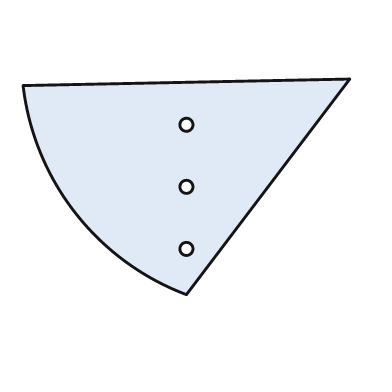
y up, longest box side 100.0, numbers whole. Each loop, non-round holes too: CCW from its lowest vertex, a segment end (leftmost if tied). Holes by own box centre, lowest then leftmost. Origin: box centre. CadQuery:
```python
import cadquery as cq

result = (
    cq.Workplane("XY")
    .moveTo(0.0, -33.0)
    .lineTo(50.0, 33.0)
    .lineTo(-50.0, 31.0)
    .threePointArc((-34.0, -8.0), (0.0, -33.0))
    .close()
    .moveTo(0.0, -19.0)
    .circle(2.0)
    .moveTo(0.0, 0.0)
    .circle(2.0)
    .moveTo(0.0, 19.0)
    .circle(2.0)
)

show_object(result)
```